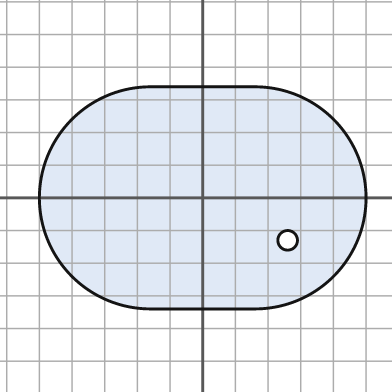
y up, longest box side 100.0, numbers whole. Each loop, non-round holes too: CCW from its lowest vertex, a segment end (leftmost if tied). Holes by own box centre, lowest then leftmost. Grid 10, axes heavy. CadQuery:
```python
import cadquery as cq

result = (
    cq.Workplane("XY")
    .moveTo(-16.0, -34.0)
    .lineTo(16.0, -34.0)
    .threePointArc((50.0, 0.0), (16.0, 34.0))
    .lineTo(-16.0, 34.0)
    .threePointArc((-50.0, 0.0), (-16.0, -34.0))
    .close()
    .moveTo(26.0, -13.0)
    .circle(3.0)
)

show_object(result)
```